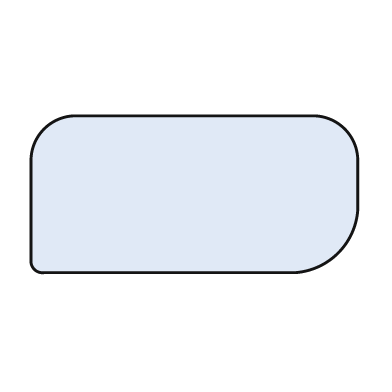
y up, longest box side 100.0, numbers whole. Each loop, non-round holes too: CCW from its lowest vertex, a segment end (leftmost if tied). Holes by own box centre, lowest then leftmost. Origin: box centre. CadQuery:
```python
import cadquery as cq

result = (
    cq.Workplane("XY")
    .moveTo(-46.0, -24.0)
    .lineTo(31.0, -24.0)
    .threePointArc((44.0, -18.0), (50.0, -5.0))
    .lineTo(50.0, 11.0)
    .threePointArc((46.0, 20.0), (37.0, 24.0))
    .lineTo(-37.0, 24.0)
    .threePointArc((-46.0, 20.0), (-50.0, 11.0))
    .lineTo(-50.0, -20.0)
    .threePointArc((-49.0, -23.0), (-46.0, -24.0))
    .close()
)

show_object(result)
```